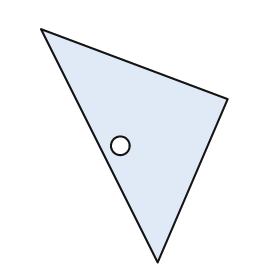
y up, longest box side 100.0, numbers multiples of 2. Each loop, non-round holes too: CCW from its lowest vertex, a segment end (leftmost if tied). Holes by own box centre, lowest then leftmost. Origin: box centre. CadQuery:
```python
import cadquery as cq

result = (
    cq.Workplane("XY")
    .moveTo(10.0, -50.0)
    .lineTo(40.0, 20.0)
    .lineTo(-40.0, 50.0)
    .close()
    .moveTo(-6.0, 0.0)
    .circle(4.0)
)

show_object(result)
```